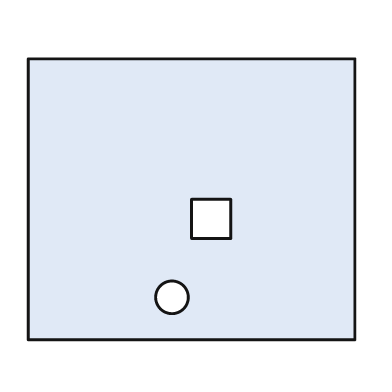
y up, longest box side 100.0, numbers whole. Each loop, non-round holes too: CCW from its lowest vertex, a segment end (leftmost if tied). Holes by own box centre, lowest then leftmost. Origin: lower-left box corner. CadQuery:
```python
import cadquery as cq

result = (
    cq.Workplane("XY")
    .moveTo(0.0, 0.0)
    .lineTo(100.0, 0.0)
    .lineTo(100.0, 86.0)
    .lineTo(0.0, 86.0)
    .close()
    .moveTo(44.0, 13.0)
    .circle(5.0)
    .moveTo(50.0, 31.0)
    .lineTo(62.0, 31.0)
    .lineTo(62.0, 43.0)
    .lineTo(50.0, 43.0)
    .close()
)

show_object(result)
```